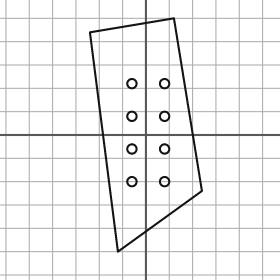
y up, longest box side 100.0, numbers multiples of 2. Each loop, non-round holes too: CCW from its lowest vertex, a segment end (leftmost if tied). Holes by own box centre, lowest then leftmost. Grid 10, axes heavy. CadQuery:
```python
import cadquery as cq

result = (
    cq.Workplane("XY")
    .moveTo(-12.0, -50.0)
    .lineTo(24.0, -24.0)
    .lineTo(12.0, 50.0)
    .lineTo(-24.0, 44.0)
    .close()
    .moveTo(-6.0, -20.0)
    .circle(2.0)
    .moveTo(8.0, -20.0)
    .circle(2.0)
    .moveTo(-6.0, -6.0)
    .circle(2.0)
    .moveTo(8.0, -6.0)
    .circle(2.0)
    .moveTo(-6.0, 8.0)
    .circle(2.0)
    .moveTo(8.0, 8.0)
    .circle(2.0)
    .moveTo(-6.0, 22.0)
    .circle(2.0)
    .moveTo(8.0, 22.0)
    .circle(2.0)
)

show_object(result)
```